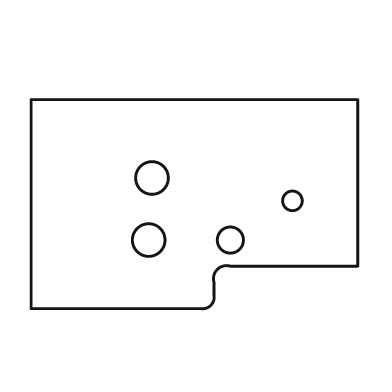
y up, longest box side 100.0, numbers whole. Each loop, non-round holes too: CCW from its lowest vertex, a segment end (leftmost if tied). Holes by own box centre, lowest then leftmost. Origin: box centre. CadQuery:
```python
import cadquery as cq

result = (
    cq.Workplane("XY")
    .moveTo(-50.0, -32.0)
    .lineTo(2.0, -32.0)
    .threePointArc((5.0, -31.0), (6.0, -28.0))
    .lineTo(6.0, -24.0)
    .threePointArc((7.0, -20.0), (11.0, -19.0))
    .lineTo(50.0, -19.0)
    .lineTo(50.0, 32.0)
    .lineTo(-50.0, 32.0)
    .close()
    .moveTo(-14.0, -11.0)
    .circle(5.0)
    .moveTo(11.0, -11.0)
    .circle(4.0)
    .moveTo(30.0, 1.0)
    .circle(3.0)
    .moveTo(-13.0, 8.0)
    .circle(5.0)
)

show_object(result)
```